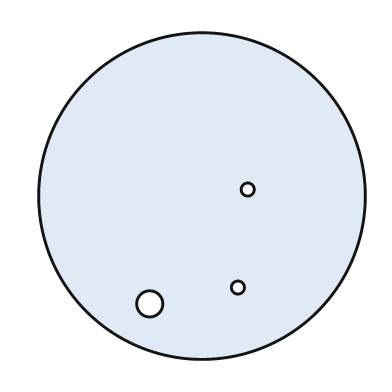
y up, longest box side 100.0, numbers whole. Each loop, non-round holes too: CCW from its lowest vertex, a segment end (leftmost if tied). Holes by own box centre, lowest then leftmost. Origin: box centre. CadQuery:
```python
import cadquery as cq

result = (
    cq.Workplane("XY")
    .moveTo(0.0, 0.0)
    .circle(50.0)
    .moveTo(-16.0, -33.0)
    .circle(4.0)
    .moveTo(11.0, -28.0)
    .circle(2.0)
    .moveTo(14.0, 2.0)
    .circle(2.0)
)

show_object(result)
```